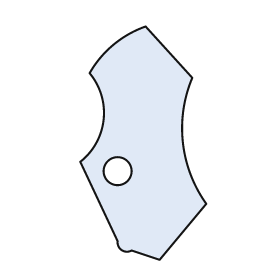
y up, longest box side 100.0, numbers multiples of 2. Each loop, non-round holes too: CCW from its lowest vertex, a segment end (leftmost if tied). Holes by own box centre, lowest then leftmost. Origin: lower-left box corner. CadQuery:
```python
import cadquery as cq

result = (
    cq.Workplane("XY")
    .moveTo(34.0, 0.0)
    .lineTo(54.0, 24.0)
    .threePointArc((44.0, 50.0), (48.0, 78.0))
    .lineTo(28.0, 100.0)
    .threePointArc((14.0, 92.0), (4.0, 80.0))
    .threePointArc((10.0, 60.0), (0.0, 42.0))
    .lineTo(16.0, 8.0)
    .threePointArc((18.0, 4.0), (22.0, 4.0))
    .close()
    .moveTo(16.0, 38.0)
    .circle(6.0)
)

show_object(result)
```